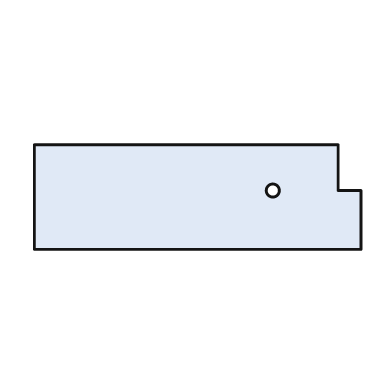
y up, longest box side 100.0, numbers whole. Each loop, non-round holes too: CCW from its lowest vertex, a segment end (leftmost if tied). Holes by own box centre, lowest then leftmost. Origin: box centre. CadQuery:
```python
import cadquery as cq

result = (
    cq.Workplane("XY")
    .moveTo(-50.0, -16.0)
    .lineTo(50.0, -16.0)
    .lineTo(50.0, 2.0)
    .lineTo(43.0, 2.0)
    .lineTo(43.0, 16.0)
    .lineTo(-50.0, 16.0)
    .close()
    .moveTo(23.0, 2.0)
    .circle(2.0)
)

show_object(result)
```